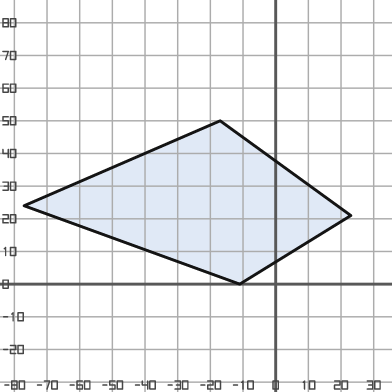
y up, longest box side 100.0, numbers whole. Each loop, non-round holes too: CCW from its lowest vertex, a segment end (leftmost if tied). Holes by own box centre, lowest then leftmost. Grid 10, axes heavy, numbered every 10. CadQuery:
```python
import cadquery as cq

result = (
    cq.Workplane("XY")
    .moveTo(-11.0, 0.0)
    .lineTo(23.0, 21.0)
    .lineTo(-17.0, 50.0)
    .lineTo(-77.0, 24.0)
    .close()
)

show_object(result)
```